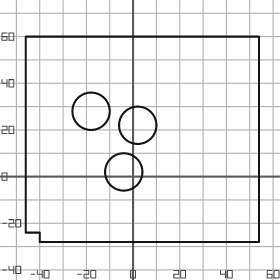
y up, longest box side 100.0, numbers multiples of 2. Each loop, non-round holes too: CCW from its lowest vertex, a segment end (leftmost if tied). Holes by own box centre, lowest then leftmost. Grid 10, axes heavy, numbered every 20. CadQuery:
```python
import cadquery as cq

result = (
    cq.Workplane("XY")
    .moveTo(-40.0, -28.0)
    .lineTo(54.0, -28.0)
    .lineTo(54.0, 60.0)
    .lineTo(-46.0, 60.0)
    .lineTo(-46.0, -24.0)
    .lineTo(-40.0, -24.0)
    .close()
    .moveTo(-4.0, 2.0)
    .circle(8.0)
    .moveTo(2.0, 22.0)
    .circle(8.0)
    .moveTo(-18.0, 28.0)
    .circle(8.0)
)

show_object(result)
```